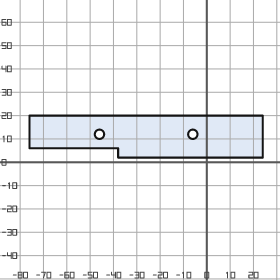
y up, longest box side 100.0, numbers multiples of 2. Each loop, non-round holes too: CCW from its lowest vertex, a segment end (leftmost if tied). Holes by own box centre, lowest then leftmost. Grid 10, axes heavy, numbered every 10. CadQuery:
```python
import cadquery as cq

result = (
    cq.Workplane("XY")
    .moveTo(-38.0, 2.0)
    .lineTo(24.0, 2.0)
    .lineTo(24.0, 20.0)
    .lineTo(-76.0, 20.0)
    .lineTo(-76.0, 6.0)
    .lineTo(-38.0, 6.0)
    .close()
    .moveTo(-46.0, 12.0)
    .circle(2.0)
    .moveTo(-6.0, 12.0)
    .circle(2.0)
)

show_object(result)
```